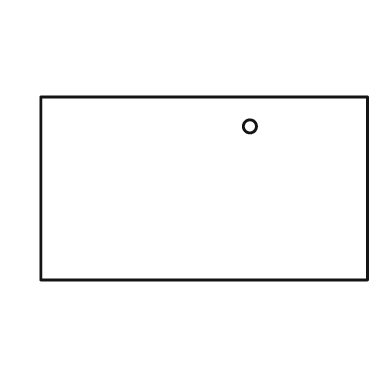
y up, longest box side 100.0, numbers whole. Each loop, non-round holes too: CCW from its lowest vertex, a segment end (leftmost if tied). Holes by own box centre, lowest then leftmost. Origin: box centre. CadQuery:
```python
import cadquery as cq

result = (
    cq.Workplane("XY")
    .moveTo(-50.0, -28.0)
    .lineTo(50.0, -28.0)
    .lineTo(50.0, 28.0)
    .lineTo(-50.0, 28.0)
    .close()
    .moveTo(14.0, 19.0)
    .circle(2.0)
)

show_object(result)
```